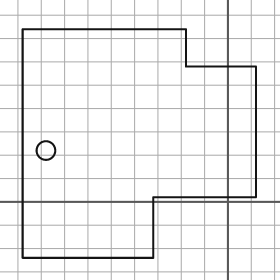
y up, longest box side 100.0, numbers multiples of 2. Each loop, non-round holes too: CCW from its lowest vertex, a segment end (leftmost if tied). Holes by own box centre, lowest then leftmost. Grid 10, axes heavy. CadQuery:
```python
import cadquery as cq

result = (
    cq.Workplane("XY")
    .moveTo(-88.0, -24.0)
    .lineTo(-32.0, -24.0)
    .lineTo(-32.0, 2.0)
    .lineTo(12.0, 2.0)
    .lineTo(12.0, 58.0)
    .lineTo(-18.0, 58.0)
    .lineTo(-18.0, 74.0)
    .lineTo(-88.0, 74.0)
    .close()
    .moveTo(-78.0, 22.0)
    .circle(4.0)
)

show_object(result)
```